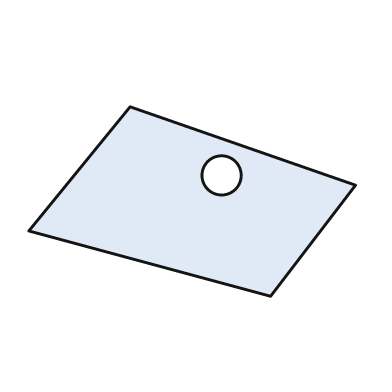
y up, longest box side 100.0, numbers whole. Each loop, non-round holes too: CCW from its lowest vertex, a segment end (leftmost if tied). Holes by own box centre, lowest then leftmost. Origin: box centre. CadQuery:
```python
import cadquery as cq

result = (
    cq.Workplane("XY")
    .moveTo(24.0, -29.0)
    .lineTo(50.0, 5.0)
    .lineTo(-19.0, 29.0)
    .lineTo(-50.0, -9.0)
    .close()
    .moveTo(9.0, 8.0)
    .circle(6.0)
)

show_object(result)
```